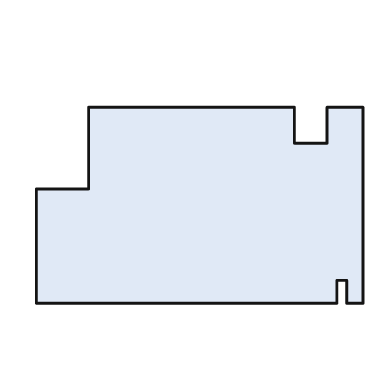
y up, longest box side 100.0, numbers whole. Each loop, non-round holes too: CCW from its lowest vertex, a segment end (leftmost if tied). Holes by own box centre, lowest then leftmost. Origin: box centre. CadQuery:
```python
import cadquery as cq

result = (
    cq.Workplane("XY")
    .moveTo(-50.0, -30.0)
    .lineTo(42.0, -30.0)
    .lineTo(42.0, -23.0)
    .lineTo(45.0, -23.0)
    .lineTo(45.0, -30.0)
    .lineTo(50.0, -30.0)
    .lineTo(50.0, 30.0)
    .lineTo(39.0, 30.0)
    .lineTo(39.0, 19.0)
    .lineTo(29.0, 19.0)
    .lineTo(29.0, 30.0)
    .lineTo(-34.0, 30.0)
    .lineTo(-34.0, 5.0)
    .lineTo(-50.0, 5.0)
    .close()
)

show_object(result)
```